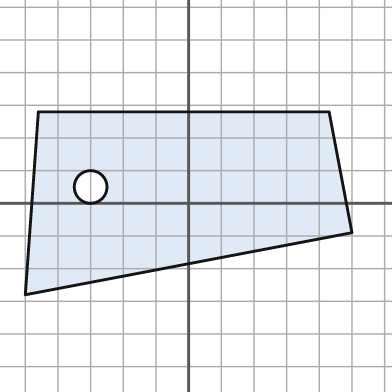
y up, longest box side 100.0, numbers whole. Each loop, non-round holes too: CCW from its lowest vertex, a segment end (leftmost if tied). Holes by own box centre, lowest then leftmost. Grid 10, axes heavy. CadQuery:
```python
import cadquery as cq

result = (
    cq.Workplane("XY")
    .moveTo(-50.0, -28.0)
    .lineTo(50.0, -9.0)
    .lineTo(43.0, 28.0)
    .lineTo(-46.0, 28.0)
    .close()
    .moveTo(-30.0, 5.0)
    .circle(5.0)
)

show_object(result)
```